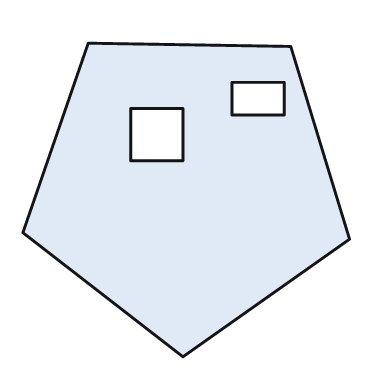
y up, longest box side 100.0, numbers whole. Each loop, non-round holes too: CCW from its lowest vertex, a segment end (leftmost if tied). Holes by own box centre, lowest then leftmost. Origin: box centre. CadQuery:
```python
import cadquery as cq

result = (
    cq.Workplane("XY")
    .moveTo(-1.0, -48.0)
    .lineTo(50.0, -12.0)
    .lineTo(32.0, 47.0)
    .lineTo(-30.0, 48.0)
    .lineTo(-50.0, -10.0)
    .close()
    .moveTo(-17.0, 12.0)
    .lineTo(-1.0, 12.0)
    .lineTo(-1.0, 28.0)
    .lineTo(-17.0, 28.0)
    .close()
    .moveTo(14.0, 26.0)
    .lineTo(30.0, 26.0)
    .lineTo(30.0, 36.0)
    .lineTo(14.0, 36.0)
    .close()
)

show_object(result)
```